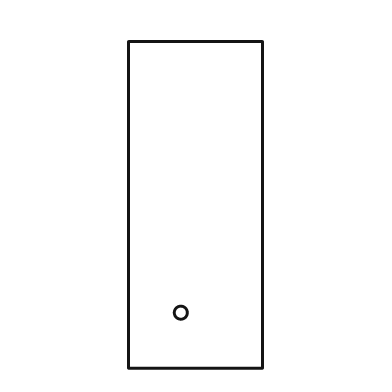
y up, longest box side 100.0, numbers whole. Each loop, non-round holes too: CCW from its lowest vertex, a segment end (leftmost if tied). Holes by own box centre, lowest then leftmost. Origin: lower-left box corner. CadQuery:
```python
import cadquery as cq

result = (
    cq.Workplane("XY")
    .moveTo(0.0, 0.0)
    .lineTo(41.0, 0.0)
    .lineTo(41.0, 100.0)
    .lineTo(0.0, 100.0)
    .close()
    .moveTo(16.0, 17.0)
    .circle(2.0)
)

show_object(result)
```